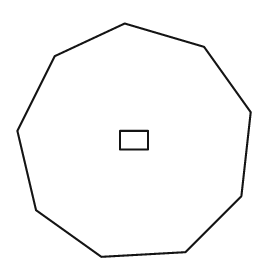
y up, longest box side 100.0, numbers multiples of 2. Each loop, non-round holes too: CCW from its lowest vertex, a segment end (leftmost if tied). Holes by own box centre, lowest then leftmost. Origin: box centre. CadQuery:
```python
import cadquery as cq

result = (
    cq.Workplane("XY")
    .moveTo(-14.0, -50.0)
    .lineTo(22.0, -48.0)
    .lineTo(46.0, -24.0)
    .lineTo(50.0, 12.0)
    .lineTo(30.0, 40.0)
    .lineTo(-4.0, 50.0)
    .lineTo(-34.0, 36.0)
    .lineTo(-50.0, 4.0)
    .lineTo(-42.0, -30.0)
    .close()
    .moveTo(-6.0, -4.0)
    .lineTo(6.0, -4.0)
    .lineTo(6.0, 4.0)
    .lineTo(-6.0, 4.0)
    .close()
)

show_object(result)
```